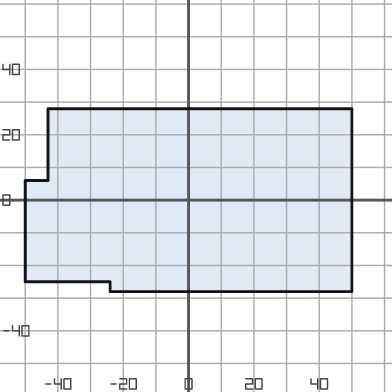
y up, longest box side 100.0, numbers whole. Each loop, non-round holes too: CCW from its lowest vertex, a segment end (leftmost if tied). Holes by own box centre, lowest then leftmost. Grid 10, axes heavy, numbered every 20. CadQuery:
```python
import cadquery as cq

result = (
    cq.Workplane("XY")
    .moveTo(-24.0, -28.0)
    .lineTo(50.0, -28.0)
    .lineTo(50.0, 28.0)
    .lineTo(-43.0, 28.0)
    .lineTo(-43.0, 6.0)
    .lineTo(-50.0, 6.0)
    .lineTo(-50.0, -25.0)
    .lineTo(-24.0, -25.0)
    .close()
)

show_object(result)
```